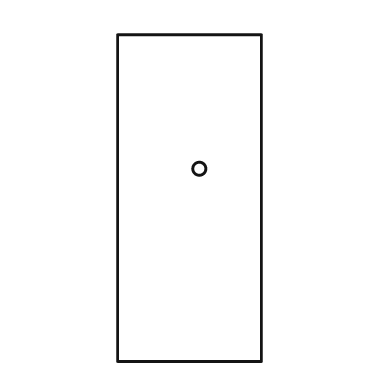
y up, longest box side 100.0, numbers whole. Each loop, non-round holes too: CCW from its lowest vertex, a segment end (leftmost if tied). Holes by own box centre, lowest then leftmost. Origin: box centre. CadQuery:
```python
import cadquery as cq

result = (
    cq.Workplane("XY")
    .moveTo(-22.0, -50.0)
    .lineTo(22.0, -50.0)
    .lineTo(22.0, 50.0)
    .lineTo(-22.0, 50.0)
    .close()
    .moveTo(3.0, 9.0)
    .circle(2.0)
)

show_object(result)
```